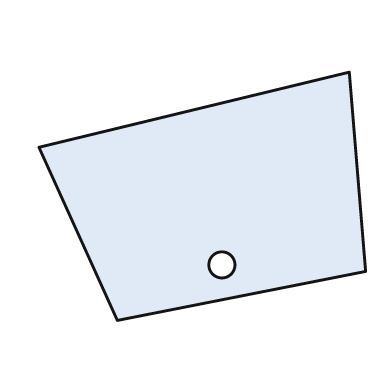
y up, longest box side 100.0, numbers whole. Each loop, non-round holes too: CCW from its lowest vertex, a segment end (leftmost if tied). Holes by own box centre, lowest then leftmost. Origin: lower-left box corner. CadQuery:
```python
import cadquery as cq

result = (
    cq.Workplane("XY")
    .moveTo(24.0, 0.0)
    .lineTo(100.0, 15.0)
    .lineTo(95.0, 76.0)
    .lineTo(0.0, 53.0)
    .close()
    .moveTo(56.0, 17.0)
    .circle(4.0)
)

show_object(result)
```